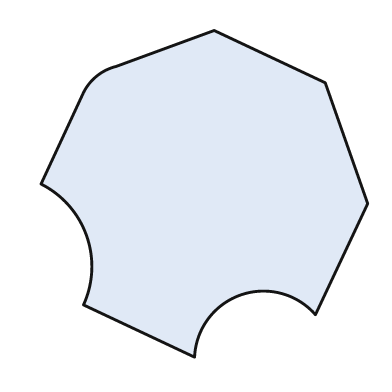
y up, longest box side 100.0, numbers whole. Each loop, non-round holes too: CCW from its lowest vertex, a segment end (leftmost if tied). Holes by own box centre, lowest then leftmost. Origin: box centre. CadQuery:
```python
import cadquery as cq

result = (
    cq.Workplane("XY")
    .moveTo(-3.0, -50.0)
    .threePointArc((11.0, -31.0), (34.0, -37.0))
    .lineTo(50.0, -3.0)
    .lineTo(37.0, 34.0)
    .lineTo(3.0, 50.0)
    .lineTo(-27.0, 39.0)
    .threePointArc((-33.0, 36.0), (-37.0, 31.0))
    .lineTo(-50.0, 3.0)
    .threePointArc((-36.0, -13.0), (-37.0, -34.0))
    .close()
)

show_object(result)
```